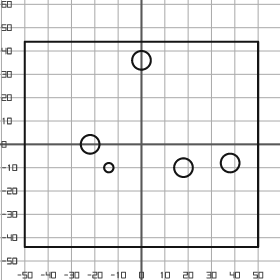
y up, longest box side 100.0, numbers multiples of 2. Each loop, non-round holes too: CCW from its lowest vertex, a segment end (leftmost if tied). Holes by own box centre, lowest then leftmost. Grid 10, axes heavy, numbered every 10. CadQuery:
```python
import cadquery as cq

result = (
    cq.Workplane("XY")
    .moveTo(-50.0, -44.0)
    .lineTo(50.0, -44.0)
    .lineTo(50.0, 44.0)
    .lineTo(-50.0, 44.0)
    .close()
    .moveTo(-14.0, -10.0)
    .circle(2.0)
    .moveTo(18.0, -10.0)
    .circle(4.0)
    .moveTo(38.0, -8.0)
    .circle(4.0)
    .moveTo(-22.0, 0.0)
    .circle(4.0)
    .moveTo(0.0, 36.0)
    .circle(4.0)
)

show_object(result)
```